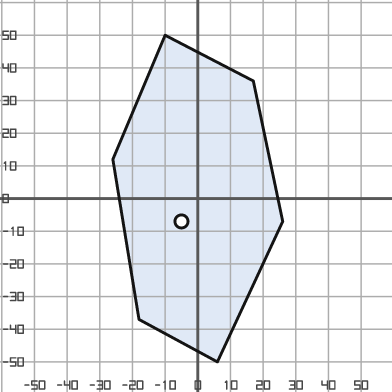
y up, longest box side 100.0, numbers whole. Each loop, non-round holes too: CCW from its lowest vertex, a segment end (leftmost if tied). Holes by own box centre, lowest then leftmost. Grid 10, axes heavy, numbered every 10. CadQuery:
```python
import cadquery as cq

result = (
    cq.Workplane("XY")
    .moveTo(6.0, -50.0)
    .lineTo(26.0, -7.0)
    .lineTo(17.0, 36.0)
    .lineTo(-10.0, 50.0)
    .lineTo(-26.0, 12.0)
    .lineTo(-18.0, -37.0)
    .close()
    .moveTo(-5.0, -7.0)
    .circle(2.0)
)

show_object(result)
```